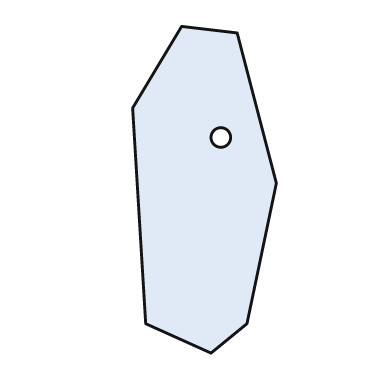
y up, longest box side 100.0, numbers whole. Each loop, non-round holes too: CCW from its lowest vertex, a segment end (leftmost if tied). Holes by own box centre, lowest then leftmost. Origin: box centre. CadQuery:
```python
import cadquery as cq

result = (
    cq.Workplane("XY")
    .moveTo(2.0, -50.0)
    .lineTo(13.0, -41.0)
    .lineTo(22.0, 2.0)
    .lineTo(10.0, 48.0)
    .lineTo(-7.0, 50.0)
    .lineTo(-22.0, 25.0)
    .lineTo(-18.0, -41.0)
    .close()
    .moveTo(5.0, 16.0)
    .circle(3.0)
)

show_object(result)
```